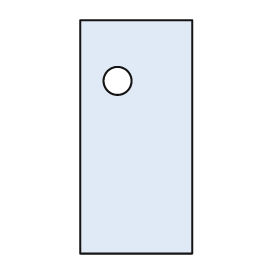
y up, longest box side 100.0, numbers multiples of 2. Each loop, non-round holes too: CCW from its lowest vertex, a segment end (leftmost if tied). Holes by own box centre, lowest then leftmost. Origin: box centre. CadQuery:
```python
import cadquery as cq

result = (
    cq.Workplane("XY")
    .moveTo(-24.0, -50.0)
    .lineTo(24.0, -50.0)
    .lineTo(24.0, 50.0)
    .lineTo(-24.0, 50.0)
    .close()
    .moveTo(-8.0, 24.0)
    .circle(6.0)
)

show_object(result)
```